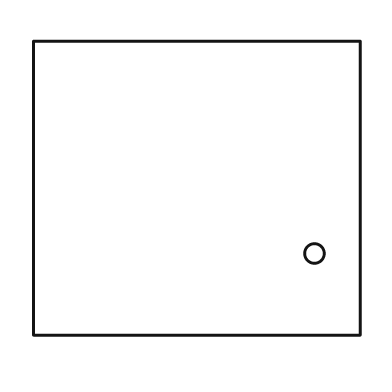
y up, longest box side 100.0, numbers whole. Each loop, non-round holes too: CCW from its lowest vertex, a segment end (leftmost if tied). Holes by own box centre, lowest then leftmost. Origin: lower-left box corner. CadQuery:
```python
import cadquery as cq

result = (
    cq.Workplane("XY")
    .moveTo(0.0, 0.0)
    .lineTo(100.0, 0.0)
    .lineTo(100.0, 90.0)
    .lineTo(0.0, 90.0)
    .close()
    .moveTo(86.0, 25.0)
    .circle(3.0)
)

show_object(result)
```